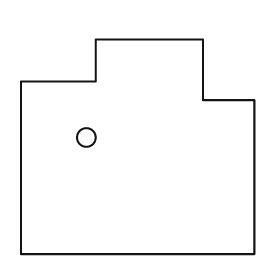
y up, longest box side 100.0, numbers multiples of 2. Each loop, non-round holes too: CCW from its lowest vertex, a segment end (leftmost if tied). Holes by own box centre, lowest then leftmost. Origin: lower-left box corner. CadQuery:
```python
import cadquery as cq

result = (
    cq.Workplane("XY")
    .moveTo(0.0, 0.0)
    .lineTo(100.0, 0.0)
    .lineTo(100.0, 66.0)
    .lineTo(78.0, 66.0)
    .lineTo(78.0, 92.0)
    .lineTo(32.0, 92.0)
    .lineTo(32.0, 74.0)
    .lineTo(0.0, 74.0)
    .close()
    .moveTo(28.0, 50.0)
    .circle(4.0)
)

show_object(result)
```